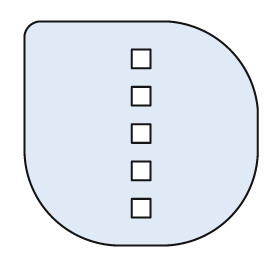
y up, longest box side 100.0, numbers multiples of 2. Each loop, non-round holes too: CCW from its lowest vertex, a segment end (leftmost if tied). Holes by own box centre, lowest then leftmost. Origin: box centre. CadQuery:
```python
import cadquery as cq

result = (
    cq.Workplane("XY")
    .moveTo(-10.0, -48.0)
    .lineTo(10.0, -48.0)
    .threePointArc((38.0, -36.0), (50.0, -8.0))
    .lineTo(50.0, 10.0)
    .threePointArc((38.0, 36.0), (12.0, 48.0))
    .lineTo(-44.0, 48.0)
    .threePointArc((-48.0, 46.0), (-50.0, 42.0))
    .lineTo(-50.0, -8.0)
    .threePointArc((-38.0, -36.0), (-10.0, -48.0))
    .close()
    .moveTo(-4.0, -36.0)
    .lineTo(4.0, -36.0)
    .lineTo(4.0, -28.0)
    .lineTo(-4.0, -28.0)
    .close()
    .moveTo(-4.0, -20.0)
    .lineTo(4.0, -20.0)
    .lineTo(4.0, -12.0)
    .lineTo(-4.0, -12.0)
    .close()
    .moveTo(-4.0, -4.0)
    .lineTo(4.0, -4.0)
    .lineTo(4.0, 4.0)
    .lineTo(-4.0, 4.0)
    .close()
    .moveTo(-4.0, 12.0)
    .lineTo(4.0, 12.0)
    .lineTo(4.0, 20.0)
    .lineTo(-4.0, 20.0)
    .close()
    .moveTo(-4.0, 28.0)
    .lineTo(4.0, 28.0)
    .lineTo(4.0, 36.0)
    .lineTo(-4.0, 36.0)
    .close()
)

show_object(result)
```